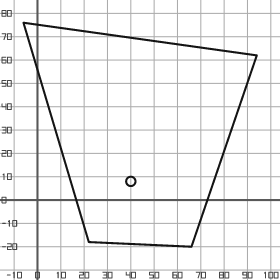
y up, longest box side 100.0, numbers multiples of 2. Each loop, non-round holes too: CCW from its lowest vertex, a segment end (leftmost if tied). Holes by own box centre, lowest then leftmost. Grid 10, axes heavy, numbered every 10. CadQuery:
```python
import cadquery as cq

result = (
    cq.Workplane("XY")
    .moveTo(66.0, -20.0)
    .lineTo(94.0, 62.0)
    .lineTo(-6.0, 76.0)
    .lineTo(22.0, -18.0)
    .close()
    .moveTo(40.0, 8.0)
    .circle(2.0)
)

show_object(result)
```